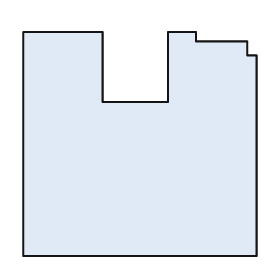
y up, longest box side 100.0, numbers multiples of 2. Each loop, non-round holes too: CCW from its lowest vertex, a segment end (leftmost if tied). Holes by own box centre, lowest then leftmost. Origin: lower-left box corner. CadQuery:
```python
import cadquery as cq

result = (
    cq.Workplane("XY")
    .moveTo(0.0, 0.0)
    .lineTo(100.0, 0.0)
    .lineTo(100.0, 86.0)
    .lineTo(96.0, 86.0)
    .lineTo(96.0, 92.0)
    .lineTo(74.0, 92.0)
    .lineTo(74.0, 96.0)
    .lineTo(62.0, 96.0)
    .lineTo(62.0, 66.0)
    .lineTo(34.0, 66.0)
    .lineTo(34.0, 96.0)
    .lineTo(0.0, 96.0)
    .close()
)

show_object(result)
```